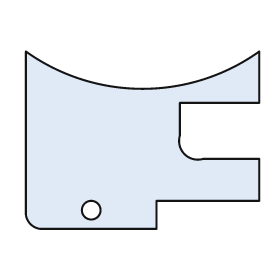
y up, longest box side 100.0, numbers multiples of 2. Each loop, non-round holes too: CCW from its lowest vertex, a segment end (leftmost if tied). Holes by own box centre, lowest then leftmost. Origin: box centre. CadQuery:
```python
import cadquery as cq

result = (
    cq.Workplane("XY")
    .moveTo(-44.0, -38.0)
    .lineTo(6.0, -38.0)
    .lineTo(6.0, -26.0)
    .lineTo(50.0, -26.0)
    .lineTo(50.0, -8.0)
    .lineTo(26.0, -8.0)
    .threePointArc((18.0, -6.0), (16.0, 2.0))
    .lineTo(16.0, 16.0)
    .lineTo(50.0, 16.0)
    .lineTo(50.0, 38.0)
    .threePointArc((0.0, 22.0), (-50.0, 38.0))
    .lineTo(-50.0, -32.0)
    .threePointArc((-48.0, -36.0), (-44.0, -38.0))
    .close()
    .moveTo(-22.0, -30.0)
    .circle(4.0)
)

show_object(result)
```